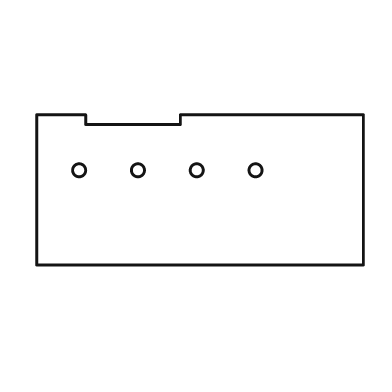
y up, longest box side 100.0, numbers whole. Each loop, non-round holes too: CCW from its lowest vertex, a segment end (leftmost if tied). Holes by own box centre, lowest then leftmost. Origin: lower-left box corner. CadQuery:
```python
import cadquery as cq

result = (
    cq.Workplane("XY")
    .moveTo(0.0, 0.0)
    .lineTo(100.0, 0.0)
    .lineTo(100.0, 46.0)
    .lineTo(44.0, 46.0)
    .lineTo(44.0, 43.0)
    .lineTo(15.0, 43.0)
    .lineTo(15.0, 46.0)
    .lineTo(0.0, 46.0)
    .close()
    .moveTo(13.0, 29.0)
    .circle(2.0)
    .moveTo(31.0, 29.0)
    .circle(2.0)
    .moveTo(49.0, 29.0)
    .circle(2.0)
    .moveTo(67.0, 29.0)
    .circle(2.0)
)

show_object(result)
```